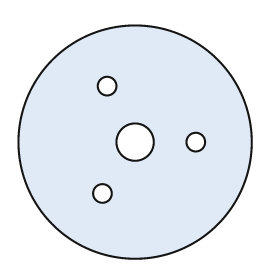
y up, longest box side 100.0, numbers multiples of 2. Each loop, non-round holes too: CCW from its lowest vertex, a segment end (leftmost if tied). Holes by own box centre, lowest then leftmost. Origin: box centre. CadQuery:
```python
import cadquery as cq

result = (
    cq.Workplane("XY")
    .moveTo(0.0, 0.0)
    .circle(50.0)
    .moveTo(-14.0, -22.0)
    .circle(4.0)
    .moveTo(0.0, 0.0)
    .circle(8.0)
    .moveTo(26.0, 0.0)
    .circle(4.0)
    .moveTo(-12.0, 24.0)
    .circle(4.0)
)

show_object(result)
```